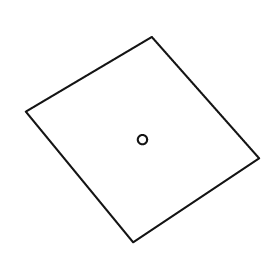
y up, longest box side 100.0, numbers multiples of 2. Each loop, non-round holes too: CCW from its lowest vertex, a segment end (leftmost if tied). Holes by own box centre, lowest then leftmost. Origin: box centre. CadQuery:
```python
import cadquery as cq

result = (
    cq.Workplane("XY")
    .moveTo(-4.0, -44.0)
    .lineTo(50.0, -8.0)
    .lineTo(4.0, 44.0)
    .lineTo(-50.0, 12.0)
    .close()
    .moveTo(0.0, 0.0)
    .circle(2.0)
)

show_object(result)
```